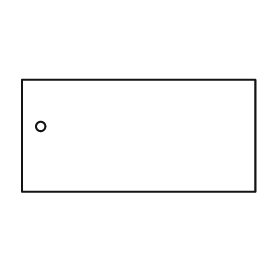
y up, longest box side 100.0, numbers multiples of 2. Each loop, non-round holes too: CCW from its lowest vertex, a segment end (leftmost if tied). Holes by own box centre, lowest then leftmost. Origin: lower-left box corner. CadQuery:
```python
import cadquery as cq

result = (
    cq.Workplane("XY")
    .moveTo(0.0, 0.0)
    .lineTo(100.0, 0.0)
    .lineTo(100.0, 48.0)
    .lineTo(0.0, 48.0)
    .close()
    .moveTo(8.0, 28.0)
    .circle(2.0)
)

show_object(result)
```